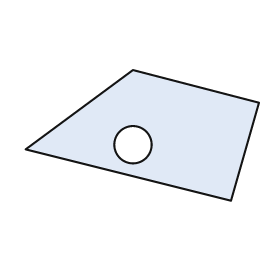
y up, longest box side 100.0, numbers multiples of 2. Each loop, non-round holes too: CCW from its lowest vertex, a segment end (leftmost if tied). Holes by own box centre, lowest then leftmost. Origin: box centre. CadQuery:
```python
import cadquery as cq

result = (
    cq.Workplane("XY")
    .moveTo(38.0, -28.0)
    .lineTo(50.0, 14.0)
    .lineTo(-4.0, 28.0)
    .lineTo(-50.0, -6.0)
    .close()
    .moveTo(-4.0, -4.0)
    .circle(8.0)
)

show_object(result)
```